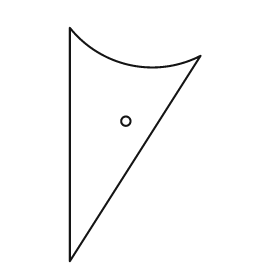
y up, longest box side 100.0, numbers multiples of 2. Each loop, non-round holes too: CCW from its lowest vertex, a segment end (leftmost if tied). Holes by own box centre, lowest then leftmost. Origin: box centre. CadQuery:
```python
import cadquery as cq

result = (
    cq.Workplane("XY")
    .moveTo(-28.0, -50.0)
    .lineTo(28.0, 38.0)
    .threePointArc((-2.0, 34.0), (-28.0, 50.0))
    .close()
    .moveTo(-4.0, 10.0)
    .circle(2.0)
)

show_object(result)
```